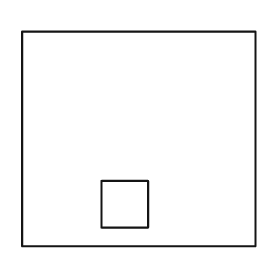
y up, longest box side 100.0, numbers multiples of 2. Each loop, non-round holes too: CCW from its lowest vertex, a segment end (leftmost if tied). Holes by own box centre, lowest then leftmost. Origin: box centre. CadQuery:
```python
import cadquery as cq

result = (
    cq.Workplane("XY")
    .moveTo(-50.0, -46.0)
    .lineTo(50.0, -46.0)
    .lineTo(50.0, 46.0)
    .lineTo(-50.0, 46.0)
    .close()
    .moveTo(-16.0, -38.0)
    .lineTo(4.0, -38.0)
    .lineTo(4.0, -18.0)
    .lineTo(-16.0, -18.0)
    .close()
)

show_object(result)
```